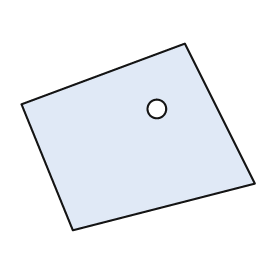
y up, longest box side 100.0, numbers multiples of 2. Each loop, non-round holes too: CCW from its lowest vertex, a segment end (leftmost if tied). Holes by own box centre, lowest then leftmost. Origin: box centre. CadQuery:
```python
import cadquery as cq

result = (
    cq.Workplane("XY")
    .moveTo(-28.0, -40.0)
    .lineTo(50.0, -20.0)
    .lineTo(20.0, 40.0)
    .lineTo(-50.0, 14.0)
    .close()
    .moveTo(8.0, 12.0)
    .circle(4.0)
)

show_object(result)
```